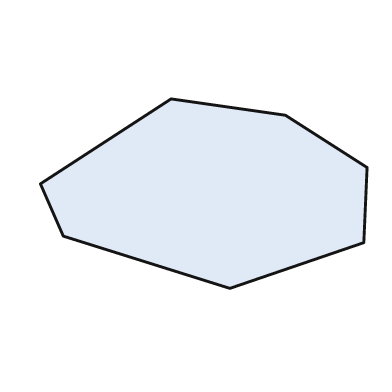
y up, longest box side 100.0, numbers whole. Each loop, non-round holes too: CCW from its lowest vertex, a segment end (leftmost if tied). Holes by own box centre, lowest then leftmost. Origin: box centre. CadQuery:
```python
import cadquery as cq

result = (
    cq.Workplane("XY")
    .moveTo(8.0, -29.0)
    .lineTo(49.0, -15.0)
    .lineTo(50.0, 8.0)
    .lineTo(25.0, 24.0)
    .lineTo(-10.0, 29.0)
    .lineTo(-50.0, 3.0)
    .lineTo(-43.0, -13.0)
    .close()
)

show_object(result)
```